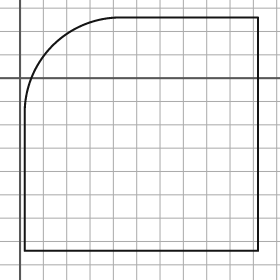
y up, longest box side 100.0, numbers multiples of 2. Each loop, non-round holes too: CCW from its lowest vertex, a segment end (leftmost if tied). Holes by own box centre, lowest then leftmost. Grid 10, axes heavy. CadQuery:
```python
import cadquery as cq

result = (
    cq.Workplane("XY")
    .moveTo(2.0, -74.0)
    .lineTo(102.0, -74.0)
    .lineTo(102.0, 26.0)
    .lineTo(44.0, 26.0)
    .threePointArc((14.0, 14.0), (2.0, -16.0))
    .close()
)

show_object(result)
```